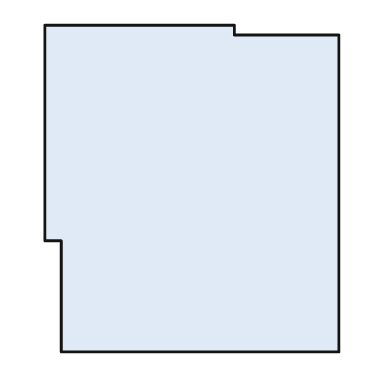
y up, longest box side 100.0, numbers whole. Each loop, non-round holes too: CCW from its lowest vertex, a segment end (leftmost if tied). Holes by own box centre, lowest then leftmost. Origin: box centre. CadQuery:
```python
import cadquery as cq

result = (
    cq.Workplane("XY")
    .moveTo(-40.0, -50.0)
    .lineTo(45.0, -50.0)
    .lineTo(45.0, 47.0)
    .lineTo(13.0, 47.0)
    .lineTo(13.0, 50.0)
    .lineTo(-45.0, 50.0)
    .lineTo(-45.0, -16.0)
    .lineTo(-40.0, -16.0)
    .close()
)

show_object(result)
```